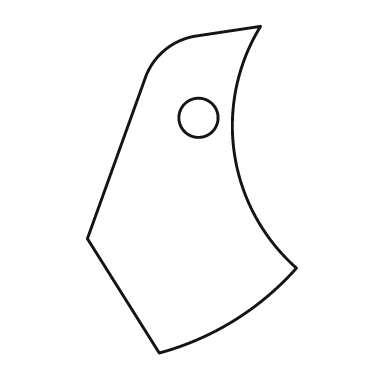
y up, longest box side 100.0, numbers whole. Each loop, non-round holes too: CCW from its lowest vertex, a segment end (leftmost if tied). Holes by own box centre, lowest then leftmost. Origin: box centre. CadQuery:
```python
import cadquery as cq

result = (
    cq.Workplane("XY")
    .moveTo(-10.0, -50.0)
    .threePointArc((13.0, -40.0), (32.0, -24.0))
    .threePointArc((13.0, 11.0), (21.0, 50.0))
    .lineTo(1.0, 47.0)
    .threePointArc((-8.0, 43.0), (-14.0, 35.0))
    .lineTo(-32.0, -15.0)
    .close()
    .moveTo(2.0, 22.0)
    .circle(6.0)
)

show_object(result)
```